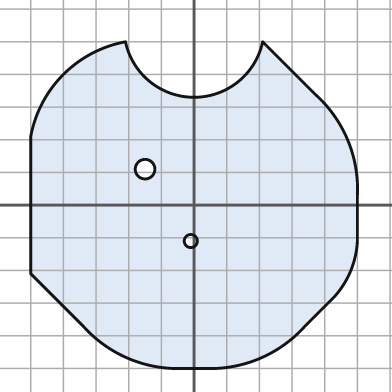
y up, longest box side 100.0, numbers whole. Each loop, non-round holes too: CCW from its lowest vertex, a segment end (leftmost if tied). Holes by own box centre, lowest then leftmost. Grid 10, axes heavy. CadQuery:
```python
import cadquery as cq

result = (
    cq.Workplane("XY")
    .moveTo(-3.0, -50.0)
    .lineTo(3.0, -50.0)
    .threePointArc((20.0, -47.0), (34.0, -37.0))
    .lineTo(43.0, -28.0)
    .threePointArc((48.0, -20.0), (50.0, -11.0))
    .lineTo(50.0, 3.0)
    .threePointArc((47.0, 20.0), (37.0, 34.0))
    .lineTo(21.0, 50.0)
    .threePointArc((0.0, 33.0), (-21.0, 50.0))
    .threePointArc((-40.0, 40.0), (-50.0, 21.0))
    .lineTo(-50.0, -21.0)
    .lineTo(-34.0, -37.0)
    .threePointArc((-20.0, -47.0), (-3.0, -50.0))
    .close()
    .moveTo(-1.0, -11.0)
    .circle(2.0)
    .moveTo(-15.0, 11.0)
    .circle(3.0)
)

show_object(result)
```